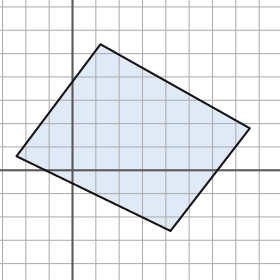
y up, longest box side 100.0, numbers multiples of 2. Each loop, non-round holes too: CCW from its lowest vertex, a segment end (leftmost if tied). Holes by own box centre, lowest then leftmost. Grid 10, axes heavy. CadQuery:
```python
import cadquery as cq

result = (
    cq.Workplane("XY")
    .moveTo(42.0, -26.0)
    .lineTo(76.0, 18.0)
    .lineTo(12.0, 54.0)
    .lineTo(-24.0, 6.0)
    .close()
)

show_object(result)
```